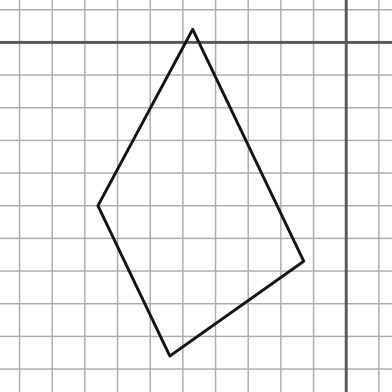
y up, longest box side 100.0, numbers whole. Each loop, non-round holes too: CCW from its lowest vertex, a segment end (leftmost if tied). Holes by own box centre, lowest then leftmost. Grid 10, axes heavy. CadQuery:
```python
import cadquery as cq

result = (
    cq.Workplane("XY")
    .moveTo(-54.0, -96.0)
    .lineTo(-13.0, -67.0)
    .lineTo(-47.0, 4.0)
    .lineTo(-76.0, -50.0)
    .close()
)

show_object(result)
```